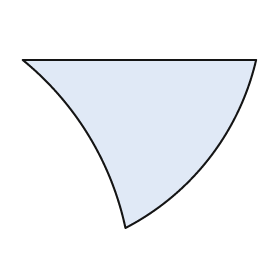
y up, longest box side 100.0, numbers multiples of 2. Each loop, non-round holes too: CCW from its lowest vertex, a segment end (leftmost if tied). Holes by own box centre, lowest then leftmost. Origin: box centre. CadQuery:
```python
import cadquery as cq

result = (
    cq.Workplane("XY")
    .moveTo(-6.0, -36.0)
    .threePointArc((30.0, -6.0), (50.0, 36.0))
    .lineTo(-50.0, 36.0)
    .threePointArc((-22.0, 4.0), (-6.0, -36.0))
    .close()
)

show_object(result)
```